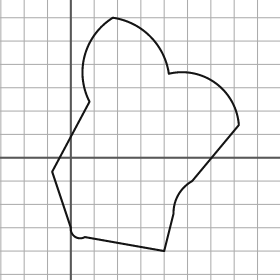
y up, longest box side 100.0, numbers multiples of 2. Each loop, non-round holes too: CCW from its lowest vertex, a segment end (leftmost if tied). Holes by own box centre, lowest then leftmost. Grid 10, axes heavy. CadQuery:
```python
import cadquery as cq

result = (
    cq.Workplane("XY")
    .moveTo(40.0, -40.0)
    .lineTo(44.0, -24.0)
    .threePointArc((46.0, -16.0), (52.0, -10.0))
    .lineTo(72.0, 14.0)
    .threePointArc((62.0, 32.0), (42.0, 36.0))
    .threePointArc((34.0, 52.0), (18.0, 60.0))
    .threePointArc((6.0, 44.0), (8.0, 24.0))
    .lineTo(-8.0, -6.0)
    .lineTo(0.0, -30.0)
    .threePointArc((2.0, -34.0), (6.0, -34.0))
    .close()
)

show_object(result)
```